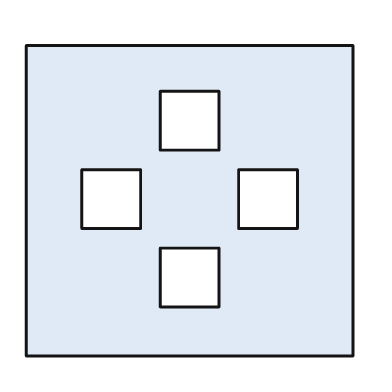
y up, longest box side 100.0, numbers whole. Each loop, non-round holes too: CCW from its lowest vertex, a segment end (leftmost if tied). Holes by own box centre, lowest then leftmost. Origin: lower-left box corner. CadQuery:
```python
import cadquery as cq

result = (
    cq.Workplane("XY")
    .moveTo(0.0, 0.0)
    .lineTo(100.0, 0.0)
    .lineTo(100.0, 95.0)
    .lineTo(0.0, 95.0)
    .close()
    .moveTo(41.0, 15.0)
    .lineTo(59.0, 15.0)
    .lineTo(59.0, 33.0)
    .lineTo(41.0, 33.0)
    .close()
    .moveTo(17.0, 39.0)
    .lineTo(35.0, 39.0)
    .lineTo(35.0, 57.0)
    .lineTo(17.0, 57.0)
    .close()
    .moveTo(65.0, 39.0)
    .lineTo(83.0, 39.0)
    .lineTo(83.0, 57.0)
    .lineTo(65.0, 57.0)
    .close()
    .moveTo(41.0, 63.0)
    .lineTo(59.0, 63.0)
    .lineTo(59.0, 81.0)
    .lineTo(41.0, 81.0)
    .close()
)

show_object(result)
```